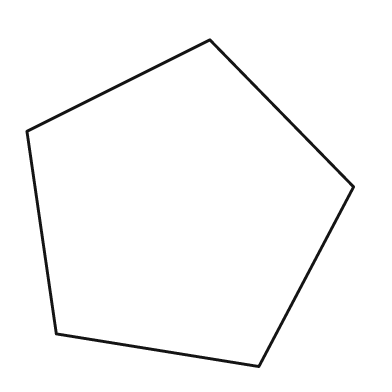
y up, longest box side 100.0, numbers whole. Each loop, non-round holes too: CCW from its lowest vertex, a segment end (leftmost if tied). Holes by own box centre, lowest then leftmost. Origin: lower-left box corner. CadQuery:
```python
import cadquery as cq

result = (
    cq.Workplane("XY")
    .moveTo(71.0, 0.0)
    .lineTo(100.0, 55.0)
    .lineTo(56.0, 100.0)
    .lineTo(0.0, 72.0)
    .lineTo(9.0, 10.0)
    .close()
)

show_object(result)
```